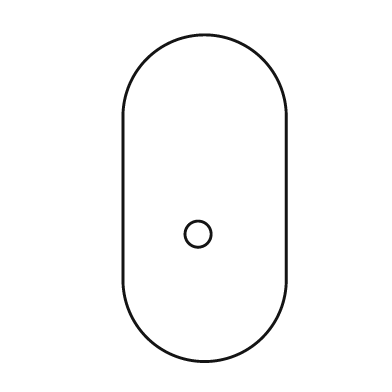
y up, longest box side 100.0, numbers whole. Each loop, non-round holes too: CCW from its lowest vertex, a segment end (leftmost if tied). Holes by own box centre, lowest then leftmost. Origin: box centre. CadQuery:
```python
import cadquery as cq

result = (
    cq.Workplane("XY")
    .moveTo(-25.0, -25.0)
    .threePointArc((0.0, -50.0), (25.0, -25.0))
    .lineTo(25.0, 25.0)
    .threePointArc((0.0, 50.0), (-25.0, 25.0))
    .close()
    .moveTo(-2.0, -11.0)
    .circle(4.0)
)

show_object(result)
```